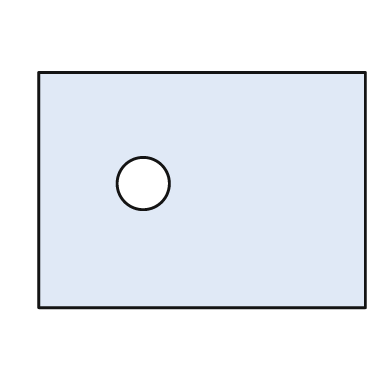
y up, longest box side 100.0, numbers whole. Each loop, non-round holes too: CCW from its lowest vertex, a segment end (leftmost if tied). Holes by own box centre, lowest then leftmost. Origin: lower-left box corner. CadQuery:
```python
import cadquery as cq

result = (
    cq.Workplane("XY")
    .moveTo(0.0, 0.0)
    .lineTo(100.0, 0.0)
    .lineTo(100.0, 72.0)
    .lineTo(0.0, 72.0)
    .close()
    .moveTo(32.0, 38.0)
    .circle(8.0)
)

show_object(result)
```